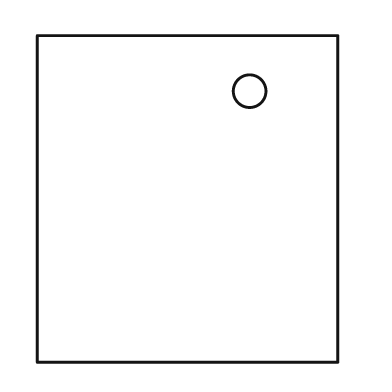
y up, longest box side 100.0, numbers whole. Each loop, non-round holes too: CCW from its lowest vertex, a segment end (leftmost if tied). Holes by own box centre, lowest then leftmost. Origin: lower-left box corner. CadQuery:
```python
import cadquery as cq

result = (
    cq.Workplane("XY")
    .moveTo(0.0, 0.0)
    .lineTo(92.0, 0.0)
    .lineTo(92.0, 100.0)
    .lineTo(0.0, 100.0)
    .close()
    .moveTo(65.0, 83.0)
    .circle(5.0)
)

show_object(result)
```